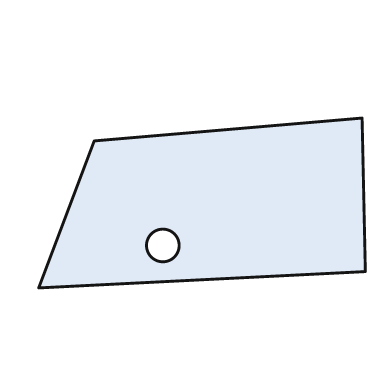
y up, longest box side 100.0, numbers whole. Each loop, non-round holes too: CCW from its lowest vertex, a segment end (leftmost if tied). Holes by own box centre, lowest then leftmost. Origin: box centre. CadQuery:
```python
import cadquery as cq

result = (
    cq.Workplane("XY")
    .moveTo(-50.0, -26.0)
    .lineTo(50.0, -21.0)
    .lineTo(49.0, 26.0)
    .lineTo(-33.0, 19.0)
    .close()
    .moveTo(-12.0, -13.0)
    .circle(5.0)
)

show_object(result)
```